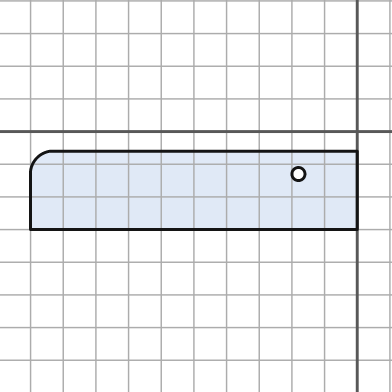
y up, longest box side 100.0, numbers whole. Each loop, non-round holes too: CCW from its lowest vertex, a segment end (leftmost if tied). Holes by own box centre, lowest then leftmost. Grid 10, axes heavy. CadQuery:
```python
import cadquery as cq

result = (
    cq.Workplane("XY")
    .moveTo(-100.0, -30.0)
    .lineTo(0.0, -30.0)
    .lineTo(0.0, -6.0)
    .lineTo(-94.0, -6.0)
    .threePointArc((-98.0, -8.0), (-100.0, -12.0))
    .close()
    .moveTo(-18.0, -13.0)
    .circle(2.0)
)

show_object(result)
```